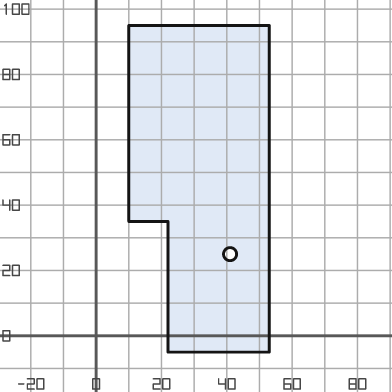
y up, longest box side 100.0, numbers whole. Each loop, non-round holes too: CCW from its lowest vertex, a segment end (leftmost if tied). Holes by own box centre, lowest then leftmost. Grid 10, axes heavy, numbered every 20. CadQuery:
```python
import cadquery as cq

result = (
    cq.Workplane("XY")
    .moveTo(22.0, -5.0)
    .lineTo(53.0, -5.0)
    .lineTo(53.0, 95.0)
    .lineTo(10.0, 95.0)
    .lineTo(10.0, 35.0)
    .lineTo(22.0, 35.0)
    .close()
    .moveTo(41.0, 25.0)
    .circle(2.0)
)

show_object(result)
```